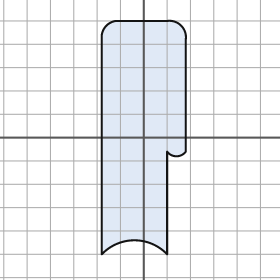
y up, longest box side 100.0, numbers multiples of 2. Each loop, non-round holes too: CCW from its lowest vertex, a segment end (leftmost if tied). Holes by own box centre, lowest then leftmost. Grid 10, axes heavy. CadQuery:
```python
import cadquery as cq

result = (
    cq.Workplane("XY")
    .moveTo(-18.0, -50.0)
    .threePointArc((-4.0, -44.0), (10.0, -50.0))
    .lineTo(10.0, -6.0)
    .threePointArc((14.0, -8.0), (18.0, -6.0))
    .lineTo(18.0, 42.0)
    .threePointArc((16.0, 48.0), (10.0, 50.0))
    .lineTo(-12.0, 50.0)
    .threePointArc((-16.0, 48.0), (-18.0, 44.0))
    .close()
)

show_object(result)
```